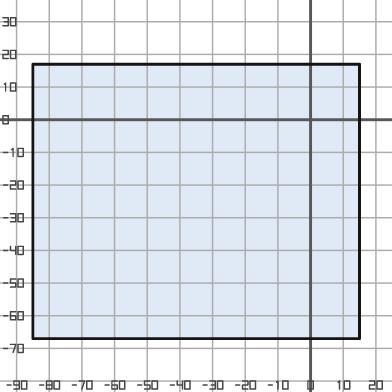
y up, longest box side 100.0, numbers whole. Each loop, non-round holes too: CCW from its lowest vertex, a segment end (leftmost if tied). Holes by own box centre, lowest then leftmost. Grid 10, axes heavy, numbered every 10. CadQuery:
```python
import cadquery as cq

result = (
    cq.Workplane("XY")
    .moveTo(-85.0, -67.0)
    .lineTo(15.0, -67.0)
    .lineTo(15.0, 17.0)
    .lineTo(-85.0, 17.0)
    .close()
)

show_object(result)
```